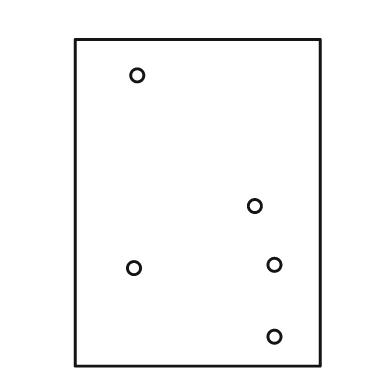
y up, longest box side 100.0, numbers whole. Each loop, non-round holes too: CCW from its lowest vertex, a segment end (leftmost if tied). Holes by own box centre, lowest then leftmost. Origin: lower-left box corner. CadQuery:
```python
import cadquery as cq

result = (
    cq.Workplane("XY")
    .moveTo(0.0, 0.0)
    .lineTo(75.0, 0.0)
    .lineTo(75.0, 100.0)
    .lineTo(0.0, 100.0)
    .close()
    .moveTo(61.0, 9.0)
    .circle(2.0)
    .moveTo(18.0, 30.0)
    .circle(2.0)
    .moveTo(61.0, 31.0)
    .circle(2.0)
    .moveTo(55.0, 49.0)
    .circle(2.0)
    .moveTo(19.0, 89.0)
    .circle(2.0)
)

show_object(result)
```